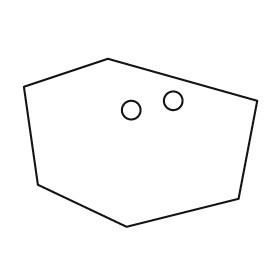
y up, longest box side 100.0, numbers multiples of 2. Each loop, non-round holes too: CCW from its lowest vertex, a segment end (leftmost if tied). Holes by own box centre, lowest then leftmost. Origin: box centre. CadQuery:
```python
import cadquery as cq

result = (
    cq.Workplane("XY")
    .moveTo(-6.0, -36.0)
    .lineTo(42.0, -24.0)
    .lineTo(50.0, 18.0)
    .lineTo(-14.0, 36.0)
    .lineTo(-50.0, 24.0)
    .lineTo(-44.0, -18.0)
    .close()
    .moveTo(-4.0, 14.0)
    .circle(4.0)
    .moveTo(14.0, 18.0)
    .circle(4.0)
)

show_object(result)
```